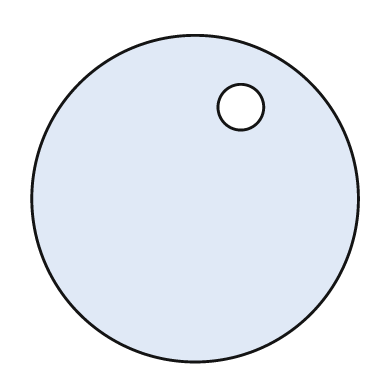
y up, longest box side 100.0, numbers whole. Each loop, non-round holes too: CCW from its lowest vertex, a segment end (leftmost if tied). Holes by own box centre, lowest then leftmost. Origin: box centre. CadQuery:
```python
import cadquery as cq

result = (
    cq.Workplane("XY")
    .moveTo(0.0, 0.0)
    .circle(50.0)
    .moveTo(14.0, 28.0)
    .circle(7.0)
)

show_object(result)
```